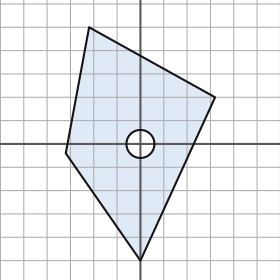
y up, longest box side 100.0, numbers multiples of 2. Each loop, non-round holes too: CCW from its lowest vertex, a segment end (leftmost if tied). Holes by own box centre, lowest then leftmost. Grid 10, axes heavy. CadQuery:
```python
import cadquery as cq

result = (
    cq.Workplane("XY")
    .moveTo(0.0, -50.0)
    .lineTo(32.0, 20.0)
    .lineTo(-22.0, 50.0)
    .lineTo(-32.0, -4.0)
    .close()
    .moveTo(0.0, 0.0)
    .circle(6.0)
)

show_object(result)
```